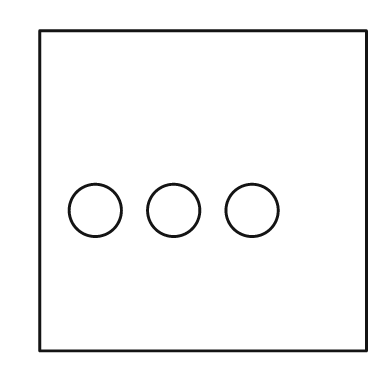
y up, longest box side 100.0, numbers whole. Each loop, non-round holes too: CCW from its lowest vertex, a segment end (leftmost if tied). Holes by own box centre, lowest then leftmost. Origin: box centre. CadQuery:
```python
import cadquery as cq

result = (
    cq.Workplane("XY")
    .moveTo(-50.0, -49.0)
    .lineTo(50.0, -49.0)
    .lineTo(50.0, 49.0)
    .lineTo(-50.0, 49.0)
    .close()
    .moveTo(-33.0, -6.0)
    .circle(8.0)
    .moveTo(-9.0, -6.0)
    .circle(8.0)
    .moveTo(15.0, -6.0)
    .circle(8.0)
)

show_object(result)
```